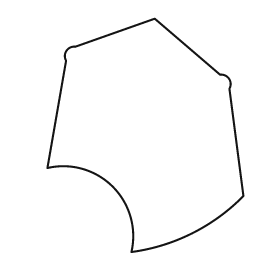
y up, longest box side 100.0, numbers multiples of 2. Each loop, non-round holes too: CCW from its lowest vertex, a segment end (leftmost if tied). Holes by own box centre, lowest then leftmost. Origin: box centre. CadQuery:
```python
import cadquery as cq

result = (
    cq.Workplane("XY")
    .moveTo(-6.0, -50.0)
    .threePointArc((20.0, -42.0), (42.0, -26.0))
    .lineTo(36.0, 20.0)
    .threePointArc((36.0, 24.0), (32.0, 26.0))
    .lineTo(4.0, 50.0)
    .lineTo(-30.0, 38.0)
    .threePointArc((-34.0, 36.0), (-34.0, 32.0))
    .lineTo(-42.0, -14.0)
    .threePointArc((-14.0, -22.0), (-6.0, -50.0))
    .close()
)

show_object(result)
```